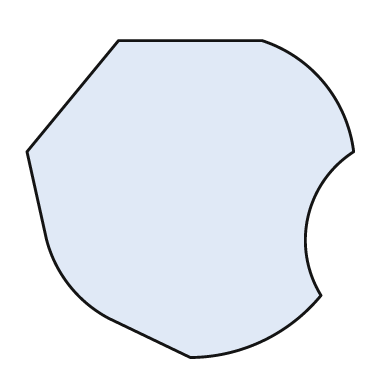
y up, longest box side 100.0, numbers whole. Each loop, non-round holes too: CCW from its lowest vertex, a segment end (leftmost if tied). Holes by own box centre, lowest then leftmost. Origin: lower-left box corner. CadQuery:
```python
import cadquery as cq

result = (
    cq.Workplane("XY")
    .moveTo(50.0, 0.0)
    .threePointArc((72.0, 5.0), (90.0, 19.0))
    .threePointArc((86.0, 43.0), (100.0, 63.0))
    .threePointArc((91.0, 84.0), (72.0, 97.0))
    .lineTo(28.0, 97.0)
    .lineTo(0.0, 63.0)
    .lineTo(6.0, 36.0)
    .threePointArc((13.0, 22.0), (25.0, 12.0))
    .close()
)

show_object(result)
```